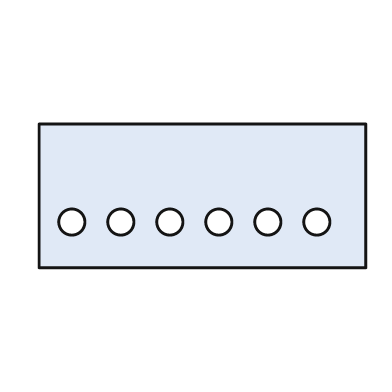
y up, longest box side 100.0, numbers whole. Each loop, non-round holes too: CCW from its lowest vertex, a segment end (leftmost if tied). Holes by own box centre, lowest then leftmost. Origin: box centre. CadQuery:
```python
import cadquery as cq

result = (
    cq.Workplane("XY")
    .moveTo(-50.0, -22.0)
    .lineTo(50.0, -22.0)
    .lineTo(50.0, 22.0)
    .lineTo(-50.0, 22.0)
    .close()
    .moveTo(-40.0, -8.0)
    .circle(4.0)
    .moveTo(-25.0, -8.0)
    .circle(4.0)
    .moveTo(-10.0, -8.0)
    .circle(4.0)
    .moveTo(5.0, -8.0)
    .circle(4.0)
    .moveTo(20.0, -8.0)
    .circle(4.0)
    .moveTo(35.0, -8.0)
    .circle(4.0)
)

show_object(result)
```